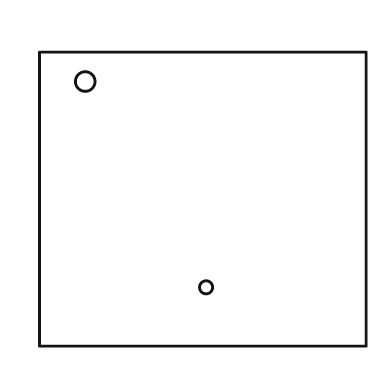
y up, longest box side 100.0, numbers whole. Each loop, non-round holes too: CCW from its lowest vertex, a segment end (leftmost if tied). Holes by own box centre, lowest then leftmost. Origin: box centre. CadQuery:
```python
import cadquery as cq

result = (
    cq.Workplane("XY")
    .moveTo(-50.0, -45.0)
    .lineTo(50.0, -45.0)
    .lineTo(50.0, 45.0)
    .lineTo(-50.0, 45.0)
    .close()
    .moveTo(1.0, -27.0)
    .circle(2.0)
    .moveTo(-36.0, 36.0)
    .circle(3.0)
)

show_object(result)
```